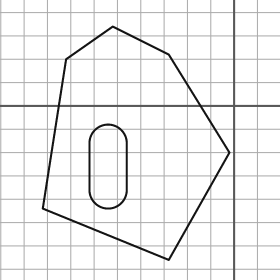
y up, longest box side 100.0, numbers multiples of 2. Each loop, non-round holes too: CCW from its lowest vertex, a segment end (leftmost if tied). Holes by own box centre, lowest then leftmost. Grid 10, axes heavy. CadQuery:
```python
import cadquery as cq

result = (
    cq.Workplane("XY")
    .moveTo(-28.0, -66.0)
    .lineTo(-2.0, -20.0)
    .lineTo(-28.0, 22.0)
    .lineTo(-52.0, 34.0)
    .lineTo(-72.0, 20.0)
    .lineTo(-82.0, -44.0)
    .close()
    .moveTo(-62.0, -36.0)
    .threePointArc((-54.0, -44.0), (-46.0, -36.0))
    .lineTo(-46.0, -16.0)
    .threePointArc((-54.0, -8.0), (-62.0, -16.0))
    .close()
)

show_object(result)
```